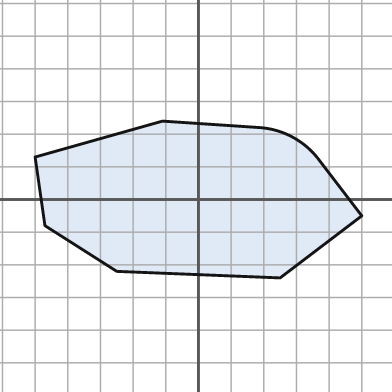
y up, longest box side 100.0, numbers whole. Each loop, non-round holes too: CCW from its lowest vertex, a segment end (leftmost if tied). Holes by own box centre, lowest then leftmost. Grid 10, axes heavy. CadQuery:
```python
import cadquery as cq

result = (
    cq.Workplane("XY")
    .moveTo(25.0, -24.0)
    .lineTo(50.0, -5.0)
    .lineTo(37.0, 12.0)
    .threePointArc((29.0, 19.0), (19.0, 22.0))
    .lineTo(-11.0, 24.0)
    .lineTo(-50.0, 13.0)
    .lineTo(-47.0, -8.0)
    .lineTo(-25.0, -22.0)
    .close()
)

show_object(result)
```